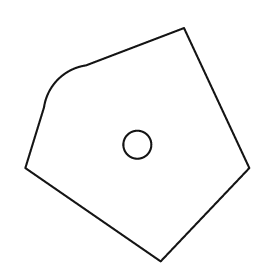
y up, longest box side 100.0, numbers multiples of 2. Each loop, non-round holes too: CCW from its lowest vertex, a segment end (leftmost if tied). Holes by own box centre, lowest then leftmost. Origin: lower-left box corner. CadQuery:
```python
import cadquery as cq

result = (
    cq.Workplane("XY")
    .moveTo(58.0, 0.0)
    .lineTo(96.0, 40.0)
    .lineTo(68.0, 100.0)
    .lineTo(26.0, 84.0)
    .threePointArc((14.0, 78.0), (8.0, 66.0))
    .lineTo(0.0, 40.0)
    .close()
    .moveTo(48.0, 50.0)
    .circle(6.0)
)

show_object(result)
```